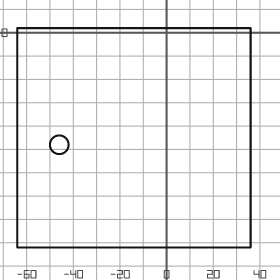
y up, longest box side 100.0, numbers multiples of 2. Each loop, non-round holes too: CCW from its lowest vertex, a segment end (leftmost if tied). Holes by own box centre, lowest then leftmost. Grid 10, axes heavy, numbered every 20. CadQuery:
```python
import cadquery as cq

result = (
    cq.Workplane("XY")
    .moveTo(-64.0, -92.0)
    .lineTo(36.0, -92.0)
    .lineTo(36.0, 2.0)
    .lineTo(-64.0, 2.0)
    .close()
    .moveTo(-46.0, -48.0)
    .circle(4.0)
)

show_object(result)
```